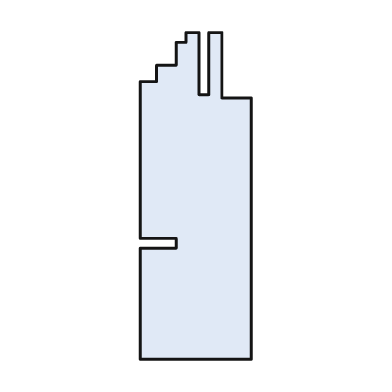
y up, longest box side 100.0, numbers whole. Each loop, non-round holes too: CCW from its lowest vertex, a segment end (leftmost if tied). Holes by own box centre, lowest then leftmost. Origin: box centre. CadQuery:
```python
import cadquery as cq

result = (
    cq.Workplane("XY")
    .moveTo(-17.0, -50.0)
    .lineTo(17.0, -50.0)
    .lineTo(17.0, 30.0)
    .lineTo(8.0, 30.0)
    .lineTo(8.0, 50.0)
    .lineTo(4.0, 50.0)
    .lineTo(4.0, 31.0)
    .lineTo(1.0, 31.0)
    .lineTo(1.0, 50.0)
    .lineTo(-3.0, 50.0)
    .lineTo(-3.0, 47.0)
    .lineTo(-6.0, 47.0)
    .lineTo(-6.0, 40.0)
    .lineTo(-12.0, 40.0)
    .lineTo(-12.0, 35.0)
    .lineTo(-17.0, 35.0)
    .lineTo(-17.0, -13.0)
    .lineTo(-6.0, -13.0)
    .lineTo(-6.0, -16.0)
    .lineTo(-17.0, -16.0)
    .close()
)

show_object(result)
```